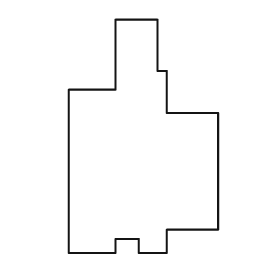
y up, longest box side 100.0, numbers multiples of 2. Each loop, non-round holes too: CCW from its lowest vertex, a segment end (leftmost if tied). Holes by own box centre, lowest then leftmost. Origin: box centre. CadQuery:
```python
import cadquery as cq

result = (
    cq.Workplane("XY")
    .moveTo(-32.0, -50.0)
    .lineTo(-12.0, -50.0)
    .lineTo(-12.0, -44.0)
    .lineTo(-2.0, -44.0)
    .lineTo(-2.0, -50.0)
    .lineTo(10.0, -50.0)
    .lineTo(10.0, -40.0)
    .lineTo(32.0, -40.0)
    .lineTo(32.0, 10.0)
    .lineTo(10.0, 10.0)
    .lineTo(10.0, 28.0)
    .lineTo(6.0, 28.0)
    .lineTo(6.0, 50.0)
    .lineTo(-12.0, 50.0)
    .lineTo(-12.0, 20.0)
    .lineTo(-32.0, 20.0)
    .close()
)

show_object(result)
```